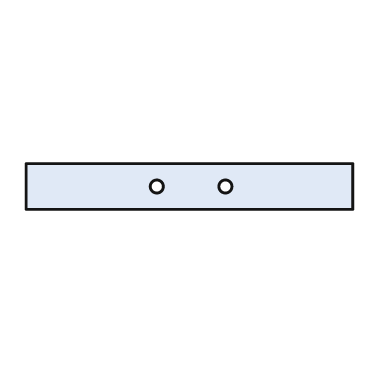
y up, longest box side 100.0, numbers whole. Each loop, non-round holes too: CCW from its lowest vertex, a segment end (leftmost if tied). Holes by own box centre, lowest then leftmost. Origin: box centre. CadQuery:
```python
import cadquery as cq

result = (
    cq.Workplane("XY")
    .moveTo(-50.0, -7.0)
    .lineTo(50.0, -7.0)
    .lineTo(50.0, 7.0)
    .lineTo(-50.0, 7.0)
    .close()
    .moveTo(-10.0, 0.0)
    .circle(2.0)
    .moveTo(11.0, 0.0)
    .circle(2.0)
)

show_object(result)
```